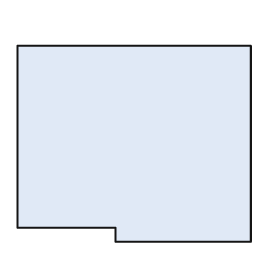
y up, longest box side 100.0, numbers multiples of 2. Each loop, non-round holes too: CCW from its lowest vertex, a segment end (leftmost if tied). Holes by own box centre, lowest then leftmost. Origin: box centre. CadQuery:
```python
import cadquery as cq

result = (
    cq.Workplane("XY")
    .moveTo(-8.0, -42.0)
    .lineTo(50.0, -42.0)
    .lineTo(50.0, 42.0)
    .lineTo(-50.0, 42.0)
    .lineTo(-50.0, -36.0)
    .lineTo(-8.0, -36.0)
    .close()
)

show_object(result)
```